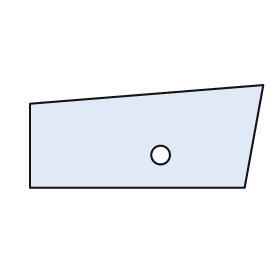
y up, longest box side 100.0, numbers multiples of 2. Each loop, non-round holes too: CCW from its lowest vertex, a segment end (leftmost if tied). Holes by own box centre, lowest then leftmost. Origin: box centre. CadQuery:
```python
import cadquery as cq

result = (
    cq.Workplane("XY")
    .moveTo(-50.0, -22.0)
    .lineTo(42.0, -22.0)
    .lineTo(50.0, 22.0)
    .lineTo(-50.0, 14.0)
    .close()
    .moveTo(6.0, -8.0)
    .circle(4.0)
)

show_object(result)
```